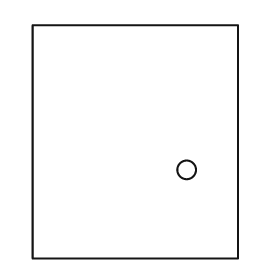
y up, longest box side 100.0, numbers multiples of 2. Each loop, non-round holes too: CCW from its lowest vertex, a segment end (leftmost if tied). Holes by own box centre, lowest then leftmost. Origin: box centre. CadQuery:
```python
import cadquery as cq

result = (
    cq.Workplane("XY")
    .moveTo(-44.0, -50.0)
    .lineTo(44.0, -50.0)
    .lineTo(44.0, 50.0)
    .lineTo(-44.0, 50.0)
    .close()
    .moveTo(22.0, -12.0)
    .circle(4.0)
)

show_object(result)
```